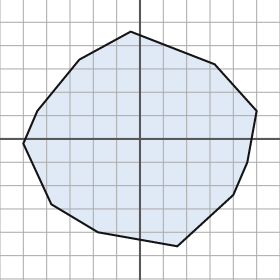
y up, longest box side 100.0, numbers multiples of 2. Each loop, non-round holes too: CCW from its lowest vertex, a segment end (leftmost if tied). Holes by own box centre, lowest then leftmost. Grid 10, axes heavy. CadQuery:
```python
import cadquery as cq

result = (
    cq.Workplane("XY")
    .moveTo(16.0, -46.0)
    .lineTo(40.0, -24.0)
    .lineTo(46.0, -10.0)
    .lineTo(50.0, 12.0)
    .lineTo(32.0, 32.0)
    .lineTo(-4.0, 46.0)
    .lineTo(-26.0, 34.0)
    .lineTo(-44.0, 12.0)
    .lineTo(-50.0, -2.0)
    .lineTo(-38.0, -28.0)
    .lineTo(-18.0, -40.0)
    .close()
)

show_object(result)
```